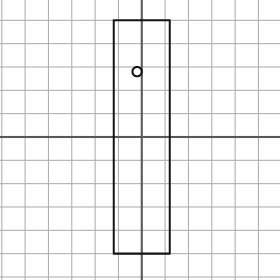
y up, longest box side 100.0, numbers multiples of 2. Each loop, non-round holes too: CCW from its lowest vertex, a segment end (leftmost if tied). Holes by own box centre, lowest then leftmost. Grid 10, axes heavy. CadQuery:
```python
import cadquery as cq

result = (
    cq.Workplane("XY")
    .moveTo(-12.0, -50.0)
    .lineTo(12.0, -50.0)
    .lineTo(12.0, 50.0)
    .lineTo(-12.0, 50.0)
    .close()
    .moveTo(-2.0, 28.0)
    .circle(2.0)
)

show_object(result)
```